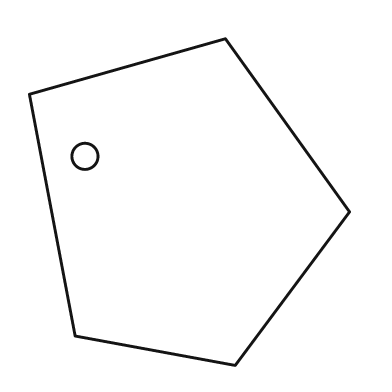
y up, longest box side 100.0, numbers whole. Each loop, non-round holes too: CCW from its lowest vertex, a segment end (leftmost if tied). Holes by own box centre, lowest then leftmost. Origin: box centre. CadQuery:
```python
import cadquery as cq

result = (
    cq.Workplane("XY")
    .moveTo(14.0, -50.0)
    .lineTo(49.0, -3.0)
    .lineTo(11.0, 50.0)
    .lineTo(-49.0, 33.0)
    .lineTo(-35.0, -41.0)
    .close()
    .moveTo(-32.0, 14.0)
    .circle(4.0)
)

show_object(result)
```